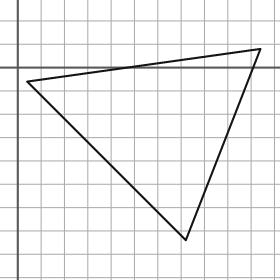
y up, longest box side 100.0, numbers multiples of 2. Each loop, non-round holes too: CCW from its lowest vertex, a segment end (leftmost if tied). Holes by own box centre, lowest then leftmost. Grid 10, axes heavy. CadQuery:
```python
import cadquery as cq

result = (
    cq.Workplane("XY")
    .moveTo(72.0, -74.0)
    .lineTo(104.0, 8.0)
    .lineTo(4.0, -6.0)
    .close()
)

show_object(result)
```